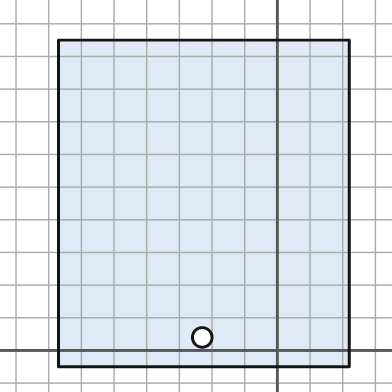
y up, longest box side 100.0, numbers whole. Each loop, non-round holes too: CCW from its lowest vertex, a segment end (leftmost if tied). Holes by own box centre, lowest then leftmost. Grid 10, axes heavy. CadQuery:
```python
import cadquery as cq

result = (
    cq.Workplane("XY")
    .moveTo(-67.0, -5.0)
    .lineTo(22.0, -5.0)
    .lineTo(22.0, 95.0)
    .lineTo(-67.0, 95.0)
    .close()
    .moveTo(-23.0, 4.0)
    .circle(3.0)
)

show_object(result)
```